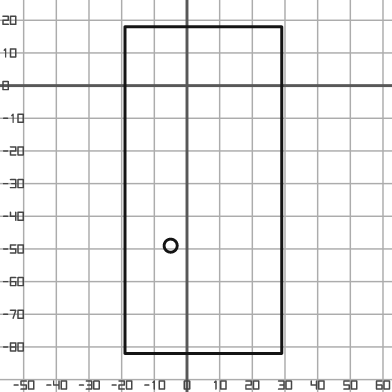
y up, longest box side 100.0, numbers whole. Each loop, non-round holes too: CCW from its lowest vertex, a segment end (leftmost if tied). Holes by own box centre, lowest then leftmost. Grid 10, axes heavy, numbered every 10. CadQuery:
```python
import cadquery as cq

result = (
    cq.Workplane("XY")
    .moveTo(-19.0, -82.0)
    .lineTo(29.0, -82.0)
    .lineTo(29.0, 18.0)
    .lineTo(-19.0, 18.0)
    .close()
    .moveTo(-5.0, -49.0)
    .circle(2.0)
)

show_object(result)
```